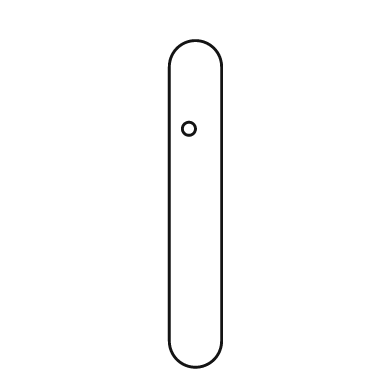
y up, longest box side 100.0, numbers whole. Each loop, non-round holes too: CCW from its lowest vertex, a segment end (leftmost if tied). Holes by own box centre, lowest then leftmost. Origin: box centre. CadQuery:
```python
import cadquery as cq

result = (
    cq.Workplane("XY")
    .moveTo(-8.0, -42.0)
    .threePointArc((0.0, -50.0), (8.0, -42.0))
    .lineTo(8.0, 42.0)
    .threePointArc((0.0, 50.0), (-8.0, 42.0))
    .close()
    .moveTo(-2.0, 23.0)
    .circle(2.0)
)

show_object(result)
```